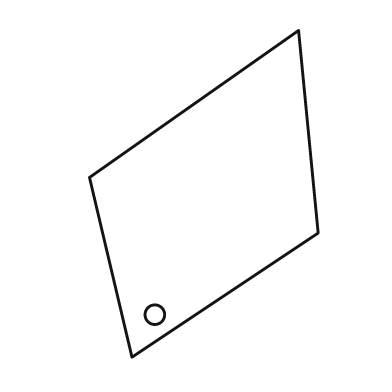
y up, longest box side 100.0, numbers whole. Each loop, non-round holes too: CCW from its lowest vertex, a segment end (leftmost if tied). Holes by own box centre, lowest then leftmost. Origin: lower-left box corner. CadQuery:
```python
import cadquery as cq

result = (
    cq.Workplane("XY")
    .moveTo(13.0, 0.0)
    .lineTo(70.0, 38.0)
    .lineTo(64.0, 100.0)
    .lineTo(0.0, 55.0)
    .close()
    .moveTo(20.0, 13.0)
    .circle(3.0)
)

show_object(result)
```